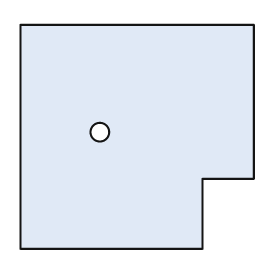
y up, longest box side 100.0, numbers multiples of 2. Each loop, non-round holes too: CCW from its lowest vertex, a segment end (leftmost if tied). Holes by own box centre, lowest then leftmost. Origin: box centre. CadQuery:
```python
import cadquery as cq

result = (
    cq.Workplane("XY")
    .moveTo(-50.0, -48.0)
    .lineTo(28.0, -48.0)
    .lineTo(28.0, -18.0)
    .lineTo(50.0, -18.0)
    .lineTo(50.0, 48.0)
    .lineTo(-50.0, 48.0)
    .close()
    .moveTo(-16.0, 2.0)
    .circle(4.0)
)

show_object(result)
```